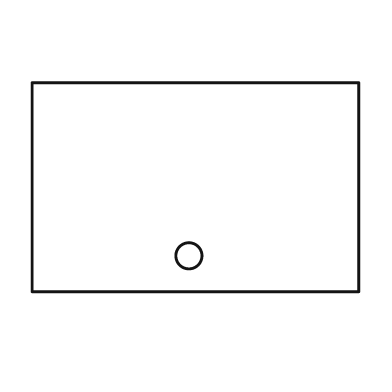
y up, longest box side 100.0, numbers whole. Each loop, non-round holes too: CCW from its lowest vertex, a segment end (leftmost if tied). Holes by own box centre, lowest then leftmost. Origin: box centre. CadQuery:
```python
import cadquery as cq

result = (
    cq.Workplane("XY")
    .moveTo(-50.0, -32.0)
    .lineTo(50.0, -32.0)
    .lineTo(50.0, 32.0)
    .lineTo(-50.0, 32.0)
    .close()
    .moveTo(-2.0, -21.0)
    .circle(4.0)
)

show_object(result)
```